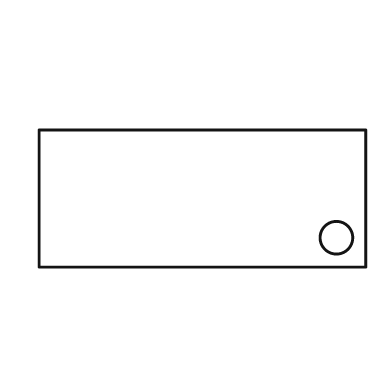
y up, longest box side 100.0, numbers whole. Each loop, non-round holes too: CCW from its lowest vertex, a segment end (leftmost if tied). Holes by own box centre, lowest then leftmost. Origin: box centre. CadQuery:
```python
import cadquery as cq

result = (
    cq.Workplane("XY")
    .moveTo(-50.0, -21.0)
    .lineTo(50.0, -21.0)
    .lineTo(50.0, 21.0)
    .lineTo(-50.0, 21.0)
    .close()
    .moveTo(41.0, -12.0)
    .circle(5.0)
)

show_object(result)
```